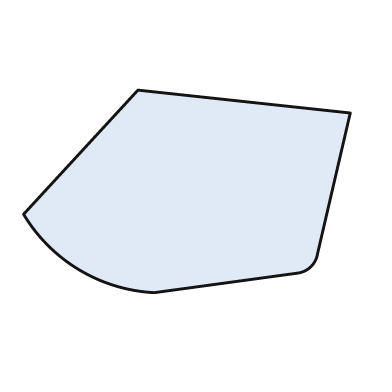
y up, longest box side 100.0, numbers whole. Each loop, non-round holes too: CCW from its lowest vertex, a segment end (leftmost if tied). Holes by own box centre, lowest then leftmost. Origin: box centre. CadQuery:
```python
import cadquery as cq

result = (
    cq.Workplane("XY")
    .moveTo(-10.0, -31.0)
    .lineTo(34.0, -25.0)
    .threePointArc((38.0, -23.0), (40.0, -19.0))
    .lineTo(50.0, 24.0)
    .lineTo(-15.0, 31.0)
    .lineTo(-50.0, -7.0)
    .threePointArc((-33.0, -24.0), (-10.0, -31.0))
    .close()
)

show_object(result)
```